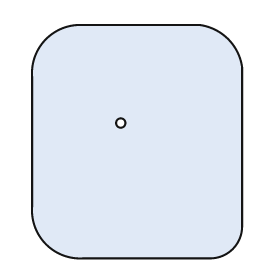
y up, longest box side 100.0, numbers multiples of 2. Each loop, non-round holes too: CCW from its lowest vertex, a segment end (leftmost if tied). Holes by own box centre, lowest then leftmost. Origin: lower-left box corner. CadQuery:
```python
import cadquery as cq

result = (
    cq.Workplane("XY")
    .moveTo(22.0, 0.0)
    .lineTo(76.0, 0.0)
    .threePointArc((86.0, 4.0), (90.0, 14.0))
    .lineTo(90.0, 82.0)
    .threePointArc((84.0, 94.0), (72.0, 100.0))
    .lineTo(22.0, 100.0)
    .threePointArc((6.0, 94.0), (0.0, 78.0))
    .lineTo(0.0, 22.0)
    .threePointArc((6.0, 6.0), (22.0, 0.0))
    .close()
    .moveTo(38.0, 58.0)
    .circle(2.0)
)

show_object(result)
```